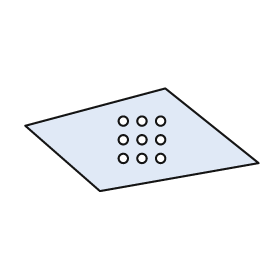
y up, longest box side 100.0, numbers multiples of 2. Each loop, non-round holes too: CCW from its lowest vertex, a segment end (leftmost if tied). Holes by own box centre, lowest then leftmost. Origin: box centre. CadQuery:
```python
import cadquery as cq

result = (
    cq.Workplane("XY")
    .moveTo(-18.0, -22.0)
    .lineTo(50.0, -10.0)
    .lineTo(10.0, 22.0)
    .lineTo(-50.0, 6.0)
    .close()
    .moveTo(-8.0, -8.0)
    .circle(2.0)
    .moveTo(0.0, -8.0)
    .circle(2.0)
    .moveTo(8.0, -8.0)
    .circle(2.0)
    .moveTo(-8.0, 0.0)
    .circle(2.0)
    .moveTo(0.0, 0.0)
    .circle(2.0)
    .moveTo(8.0, 0.0)
    .circle(2.0)
    .moveTo(-8.0, 8.0)
    .circle(2.0)
    .moveTo(0.0, 8.0)
    .circle(2.0)
    .moveTo(8.0, 8.0)
    .circle(2.0)
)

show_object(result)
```